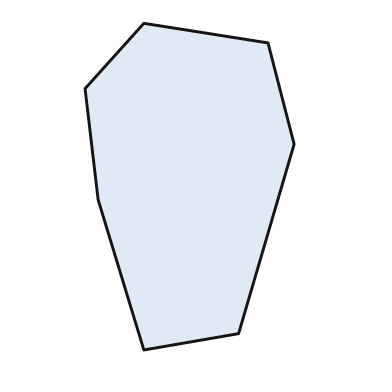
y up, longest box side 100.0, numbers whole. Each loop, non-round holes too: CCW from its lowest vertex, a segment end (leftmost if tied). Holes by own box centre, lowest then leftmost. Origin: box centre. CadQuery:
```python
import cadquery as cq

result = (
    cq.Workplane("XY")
    .moveTo(-14.0, -50.0)
    .lineTo(15.0, -45.0)
    .lineTo(32.0, 13.0)
    .lineTo(24.0, 44.0)
    .lineTo(-14.0, 50.0)
    .lineTo(-32.0, 30.0)
    .lineTo(-28.0, -4.0)
    .close()
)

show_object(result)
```